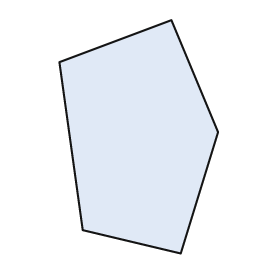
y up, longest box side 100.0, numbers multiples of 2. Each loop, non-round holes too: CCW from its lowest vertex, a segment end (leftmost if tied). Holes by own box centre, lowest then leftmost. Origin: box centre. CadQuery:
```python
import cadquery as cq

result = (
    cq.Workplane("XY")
    .moveTo(18.0, -50.0)
    .lineTo(34.0, 2.0)
    .lineTo(14.0, 50.0)
    .lineTo(-34.0, 32.0)
    .lineTo(-24.0, -40.0)
    .close()
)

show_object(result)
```